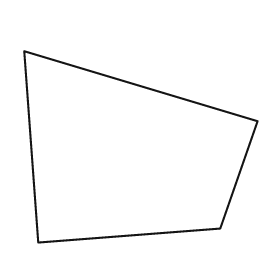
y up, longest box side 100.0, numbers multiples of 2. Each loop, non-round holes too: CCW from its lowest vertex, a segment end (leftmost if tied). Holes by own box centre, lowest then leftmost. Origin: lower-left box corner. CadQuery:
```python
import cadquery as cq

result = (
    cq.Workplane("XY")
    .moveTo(6.0, 0.0)
    .lineTo(84.0, 6.0)
    .lineTo(100.0, 52.0)
    .lineTo(0.0, 82.0)
    .close()
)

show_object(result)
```